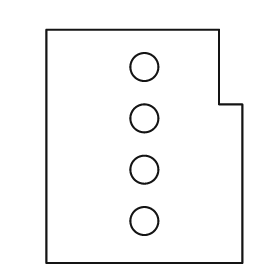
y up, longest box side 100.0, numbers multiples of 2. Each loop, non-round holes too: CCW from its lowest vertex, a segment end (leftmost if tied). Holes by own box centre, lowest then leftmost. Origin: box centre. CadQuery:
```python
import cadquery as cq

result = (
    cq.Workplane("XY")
    .moveTo(-42.0, -50.0)
    .lineTo(42.0, -50.0)
    .lineTo(42.0, 18.0)
    .lineTo(32.0, 18.0)
    .lineTo(32.0, 50.0)
    .lineTo(-42.0, 50.0)
    .close()
    .moveTo(0.0, -32.0)
    .circle(6.0)
    .moveTo(0.0, -10.0)
    .circle(6.0)
    .moveTo(0.0, 12.0)
    .circle(6.0)
    .moveTo(0.0, 34.0)
    .circle(6.0)
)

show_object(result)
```